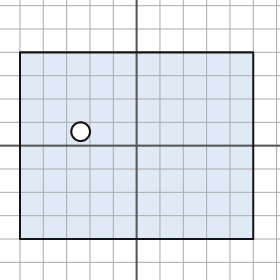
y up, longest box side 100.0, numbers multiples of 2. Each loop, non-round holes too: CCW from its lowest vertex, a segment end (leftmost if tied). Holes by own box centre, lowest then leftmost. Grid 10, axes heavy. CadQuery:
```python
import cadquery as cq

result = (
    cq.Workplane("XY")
    .moveTo(-50.0, -40.0)
    .lineTo(50.0, -40.0)
    .lineTo(50.0, 40.0)
    .lineTo(-50.0, 40.0)
    .close()
    .moveTo(-24.0, 6.0)
    .circle(4.0)
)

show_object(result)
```